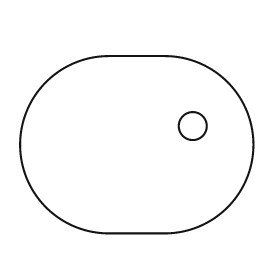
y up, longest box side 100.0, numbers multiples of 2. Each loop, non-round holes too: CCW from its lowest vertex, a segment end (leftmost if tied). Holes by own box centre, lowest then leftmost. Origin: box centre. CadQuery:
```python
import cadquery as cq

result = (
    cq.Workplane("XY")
    .moveTo(-12.0, -38.0)
    .lineTo(12.0, -38.0)
    .threePointArc((50.0, 0.0), (12.0, 38.0))
    .lineTo(-12.0, 38.0)
    .threePointArc((-50.0, 0.0), (-12.0, -38.0))
    .close()
    .moveTo(24.0, 8.0)
    .circle(6.0)
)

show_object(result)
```